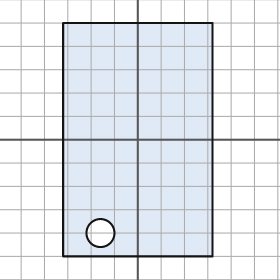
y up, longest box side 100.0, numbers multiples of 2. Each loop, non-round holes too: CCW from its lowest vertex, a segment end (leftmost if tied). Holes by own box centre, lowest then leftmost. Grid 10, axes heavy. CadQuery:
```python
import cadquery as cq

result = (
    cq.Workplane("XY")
    .moveTo(-32.0, -50.0)
    .lineTo(32.0, -50.0)
    .lineTo(32.0, 50.0)
    .lineTo(-32.0, 50.0)
    .close()
    .moveTo(-16.0, -40.0)
    .circle(6.0)
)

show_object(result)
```